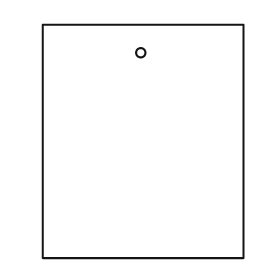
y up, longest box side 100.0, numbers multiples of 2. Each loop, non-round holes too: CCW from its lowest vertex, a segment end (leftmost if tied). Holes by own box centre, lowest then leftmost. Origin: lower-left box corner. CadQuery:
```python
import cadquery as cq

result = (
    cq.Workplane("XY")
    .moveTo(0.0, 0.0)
    .lineTo(86.0, 0.0)
    .lineTo(86.0, 100.0)
    .lineTo(0.0, 100.0)
    .close()
    .moveTo(42.0, 88.0)
    .circle(2.0)
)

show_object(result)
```